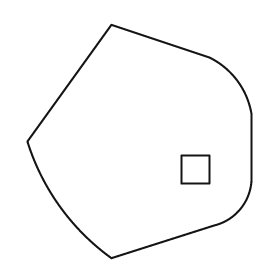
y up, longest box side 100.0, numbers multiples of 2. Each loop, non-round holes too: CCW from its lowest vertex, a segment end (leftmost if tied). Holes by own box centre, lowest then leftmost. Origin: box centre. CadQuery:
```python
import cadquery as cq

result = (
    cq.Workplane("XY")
    .moveTo(-12.0, -50.0)
    .lineTo(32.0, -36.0)
    .threePointArc((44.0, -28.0), (48.0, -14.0))
    .lineTo(48.0, 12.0)
    .threePointArc((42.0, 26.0), (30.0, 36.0))
    .lineTo(-12.0, 50.0)
    .lineTo(-48.0, 0.0)
    .threePointArc((-34.0, -28.0), (-12.0, -50.0))
    .close()
    .moveTo(18.0, -18.0)
    .lineTo(30.0, -18.0)
    .lineTo(30.0, -6.0)
    .lineTo(18.0, -6.0)
    .close()
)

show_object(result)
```